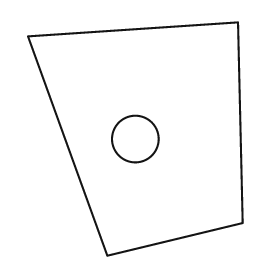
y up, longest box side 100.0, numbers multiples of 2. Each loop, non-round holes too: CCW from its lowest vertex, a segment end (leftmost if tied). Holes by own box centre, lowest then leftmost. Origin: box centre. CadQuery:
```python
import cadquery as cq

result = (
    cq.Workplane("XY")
    .moveTo(-12.0, -50.0)
    .lineTo(46.0, -36.0)
    .lineTo(44.0, 50.0)
    .lineTo(-46.0, 44.0)
    .close()
    .moveTo(0.0, 0.0)
    .circle(10.0)
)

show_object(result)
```